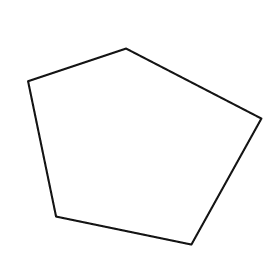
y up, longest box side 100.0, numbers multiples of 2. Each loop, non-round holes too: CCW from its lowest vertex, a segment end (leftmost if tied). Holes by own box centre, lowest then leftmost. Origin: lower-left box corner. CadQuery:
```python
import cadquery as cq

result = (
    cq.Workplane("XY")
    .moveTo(70.0, 0.0)
    .lineTo(100.0, 54.0)
    .lineTo(42.0, 84.0)
    .lineTo(0.0, 70.0)
    .lineTo(12.0, 12.0)
    .close()
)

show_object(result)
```